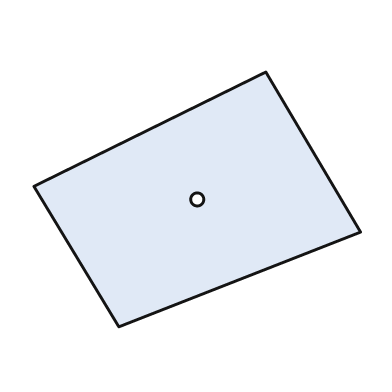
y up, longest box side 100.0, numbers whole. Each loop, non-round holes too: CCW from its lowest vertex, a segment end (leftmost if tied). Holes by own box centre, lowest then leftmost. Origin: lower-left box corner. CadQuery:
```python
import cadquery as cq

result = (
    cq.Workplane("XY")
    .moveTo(26.0, 0.0)
    .lineTo(100.0, 29.0)
    .lineTo(71.0, 78.0)
    .lineTo(0.0, 43.0)
    .close()
    .moveTo(50.0, 39.0)
    .circle(2.0)
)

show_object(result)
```